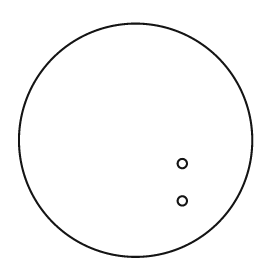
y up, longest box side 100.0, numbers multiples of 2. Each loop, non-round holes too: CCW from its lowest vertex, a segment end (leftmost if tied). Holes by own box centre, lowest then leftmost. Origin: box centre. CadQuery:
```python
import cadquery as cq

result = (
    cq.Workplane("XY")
    .moveTo(0.0, 0.0)
    .circle(50.0)
    .moveTo(20.0, -26.0)
    .circle(2.0)
    .moveTo(20.0, -10.0)
    .circle(2.0)
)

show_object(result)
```